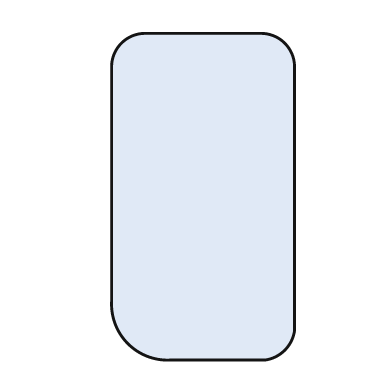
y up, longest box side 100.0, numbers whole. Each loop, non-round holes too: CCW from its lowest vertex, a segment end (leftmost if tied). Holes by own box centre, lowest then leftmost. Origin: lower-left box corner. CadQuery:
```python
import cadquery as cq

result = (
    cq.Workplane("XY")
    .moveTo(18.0, 0.0)
    .lineTo(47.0, 0.0)
    .threePointArc((53.0, 3.0), (56.0, 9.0))
    .lineTo(56.0, 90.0)
    .threePointArc((53.0, 97.0), (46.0, 100.0))
    .lineTo(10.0, 100.0)
    .threePointArc((3.0, 97.0), (0.0, 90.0))
    .lineTo(0.0, 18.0)
    .threePointArc((5.0, 5.0), (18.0, 0.0))
    .close()
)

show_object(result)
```